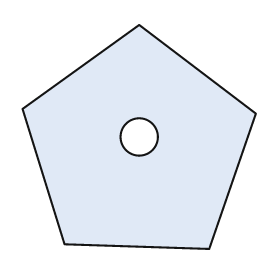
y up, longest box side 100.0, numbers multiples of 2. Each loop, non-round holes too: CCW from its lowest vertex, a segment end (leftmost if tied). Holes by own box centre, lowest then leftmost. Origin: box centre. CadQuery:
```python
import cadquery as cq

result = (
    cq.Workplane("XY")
    .moveTo(30.0, -48.0)
    .lineTo(50.0, 10.0)
    .lineTo(0.0, 48.0)
    .lineTo(-50.0, 12.0)
    .lineTo(-32.0, -46.0)
    .close()
    .moveTo(0.0, 0.0)
    .circle(8.0)
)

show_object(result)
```